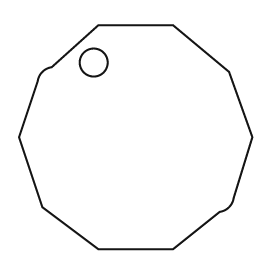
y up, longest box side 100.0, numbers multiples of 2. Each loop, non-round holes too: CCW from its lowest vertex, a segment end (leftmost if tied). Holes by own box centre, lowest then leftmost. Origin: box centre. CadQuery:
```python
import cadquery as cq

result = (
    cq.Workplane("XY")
    .moveTo(-16.0, -48.0)
    .lineTo(16.0, -48.0)
    .lineTo(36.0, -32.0)
    .threePointArc((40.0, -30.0), (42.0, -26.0))
    .lineTo(50.0, 0.0)
    .lineTo(40.0, 28.0)
    .lineTo(16.0, 48.0)
    .lineTo(-16.0, 48.0)
    .lineTo(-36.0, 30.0)
    .threePointArc((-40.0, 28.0), (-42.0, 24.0))
    .lineTo(-50.0, 0.0)
    .lineTo(-40.0, -30.0)
    .close()
    .moveTo(-18.0, 32.0)
    .circle(6.0)
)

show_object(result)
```